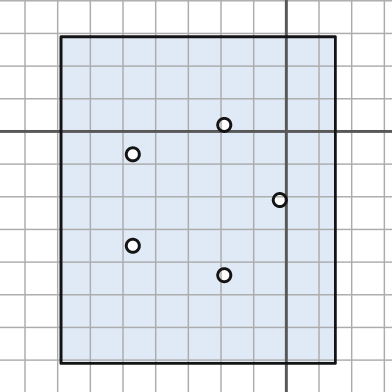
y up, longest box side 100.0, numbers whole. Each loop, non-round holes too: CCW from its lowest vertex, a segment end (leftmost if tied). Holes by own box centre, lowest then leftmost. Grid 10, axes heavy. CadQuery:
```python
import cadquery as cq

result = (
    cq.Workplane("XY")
    .moveTo(-69.0, -71.0)
    .lineTo(15.0, -71.0)
    .lineTo(15.0, 29.0)
    .lineTo(-69.0, 29.0)
    .close()
    .moveTo(-19.0, -44.0)
    .circle(2.0)
    .moveTo(-47.0, -35.0)
    .circle(2.0)
    .moveTo(-2.0, -21.0)
    .circle(2.0)
    .moveTo(-47.0, -7.0)
    .circle(2.0)
    .moveTo(-19.0, 2.0)
    .circle(2.0)
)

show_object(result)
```